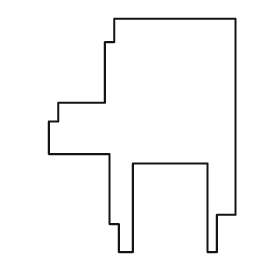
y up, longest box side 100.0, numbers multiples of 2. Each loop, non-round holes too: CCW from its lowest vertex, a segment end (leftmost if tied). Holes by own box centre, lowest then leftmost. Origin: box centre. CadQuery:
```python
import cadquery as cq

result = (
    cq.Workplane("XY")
    .moveTo(-10.0, -50.0)
    .lineTo(-4.0, -50.0)
    .lineTo(-4.0, -12.0)
    .lineTo(28.0, -12.0)
    .lineTo(28.0, -50.0)
    .lineTo(32.0, -50.0)
    .lineTo(32.0, -34.0)
    .lineTo(40.0, -34.0)
    .lineTo(40.0, 50.0)
    .lineTo(-12.0, 50.0)
    .lineTo(-12.0, 40.0)
    .lineTo(-16.0, 40.0)
    .lineTo(-16.0, 14.0)
    .lineTo(-36.0, 14.0)
    .lineTo(-36.0, 6.0)
    .lineTo(-40.0, 6.0)
    .lineTo(-40.0, -8.0)
    .lineTo(-14.0, -8.0)
    .lineTo(-14.0, -38.0)
    .lineTo(-10.0, -38.0)
    .close()
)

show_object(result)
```